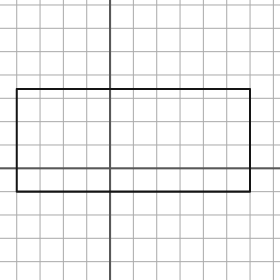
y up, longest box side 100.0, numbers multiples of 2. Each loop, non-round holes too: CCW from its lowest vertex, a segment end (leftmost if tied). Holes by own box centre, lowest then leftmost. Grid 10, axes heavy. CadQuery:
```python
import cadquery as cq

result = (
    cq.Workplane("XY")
    .moveTo(-40.0, -10.0)
    .lineTo(60.0, -10.0)
    .lineTo(60.0, 34.0)
    .lineTo(-40.0, 34.0)
    .close()
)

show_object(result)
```